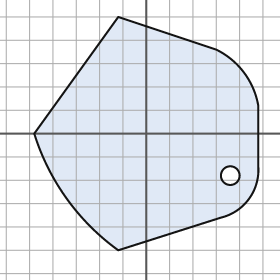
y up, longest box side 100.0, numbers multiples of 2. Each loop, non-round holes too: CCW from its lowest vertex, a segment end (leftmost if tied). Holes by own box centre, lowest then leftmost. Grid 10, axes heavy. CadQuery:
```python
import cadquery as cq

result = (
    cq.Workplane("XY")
    .moveTo(-12.0, -50.0)
    .lineTo(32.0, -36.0)
    .threePointArc((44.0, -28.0), (48.0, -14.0))
    .lineTo(48.0, 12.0)
    .threePointArc((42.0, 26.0), (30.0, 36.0))
    .lineTo(-12.0, 50.0)
    .lineTo(-48.0, 0.0)
    .threePointArc((-34.0, -28.0), (-12.0, -50.0))
    .close()
    .moveTo(36.0, -18.0)
    .circle(4.0)
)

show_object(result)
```